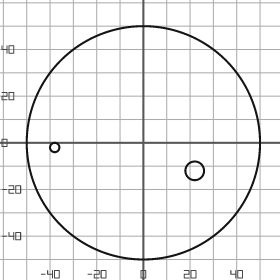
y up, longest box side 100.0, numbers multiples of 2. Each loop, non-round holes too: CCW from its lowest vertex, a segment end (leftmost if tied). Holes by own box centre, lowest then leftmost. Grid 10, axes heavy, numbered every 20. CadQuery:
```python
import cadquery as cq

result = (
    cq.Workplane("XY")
    .moveTo(0.0, 0.0)
    .circle(50.0)
    .moveTo(22.0, -12.0)
    .circle(4.0)
    .moveTo(-38.0, -2.0)
    .circle(2.0)
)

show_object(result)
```